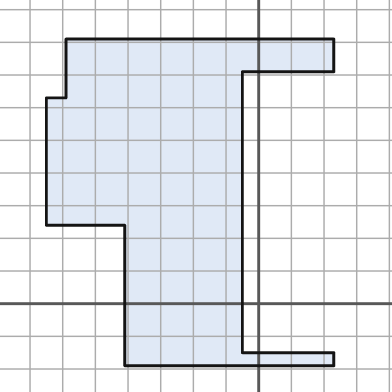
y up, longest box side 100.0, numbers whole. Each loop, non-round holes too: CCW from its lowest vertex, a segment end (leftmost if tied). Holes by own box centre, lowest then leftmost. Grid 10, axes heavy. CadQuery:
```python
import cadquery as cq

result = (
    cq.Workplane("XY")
    .moveTo(-41.0, -19.0)
    .lineTo(23.0, -19.0)
    .lineTo(23.0, -15.0)
    .lineTo(-5.0, -15.0)
    .lineTo(-5.0, 71.0)
    .lineTo(23.0, 71.0)
    .lineTo(23.0, 81.0)
    .lineTo(-59.0, 81.0)
    .lineTo(-59.0, 63.0)
    .lineTo(-65.0, 63.0)
    .lineTo(-65.0, 24.0)
    .lineTo(-41.0, 24.0)
    .close()
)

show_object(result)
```